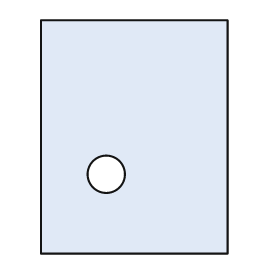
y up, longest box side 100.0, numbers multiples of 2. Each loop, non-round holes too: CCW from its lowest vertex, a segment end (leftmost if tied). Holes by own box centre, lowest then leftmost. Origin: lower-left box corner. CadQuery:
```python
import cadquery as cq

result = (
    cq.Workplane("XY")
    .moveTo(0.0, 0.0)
    .lineTo(80.0, 0.0)
    .lineTo(80.0, 100.0)
    .lineTo(0.0, 100.0)
    .close()
    .moveTo(28.0, 34.0)
    .circle(8.0)
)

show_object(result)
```